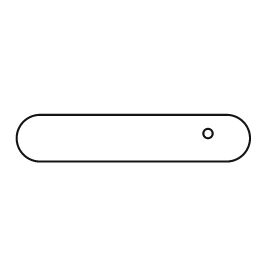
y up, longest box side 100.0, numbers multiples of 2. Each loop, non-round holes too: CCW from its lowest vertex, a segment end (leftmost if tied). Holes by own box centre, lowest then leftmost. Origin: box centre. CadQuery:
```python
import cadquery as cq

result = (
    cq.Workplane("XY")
    .moveTo(-40.0, -10.0)
    .lineTo(40.0, -10.0)
    .threePointArc((50.0, 0.0), (40.0, 10.0))
    .lineTo(-40.0, 10.0)
    .threePointArc((-50.0, 0.0), (-40.0, -10.0))
    .close()
    .moveTo(32.0, 2.0)
    .circle(2.0)
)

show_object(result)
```